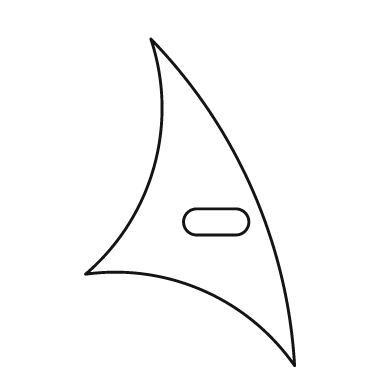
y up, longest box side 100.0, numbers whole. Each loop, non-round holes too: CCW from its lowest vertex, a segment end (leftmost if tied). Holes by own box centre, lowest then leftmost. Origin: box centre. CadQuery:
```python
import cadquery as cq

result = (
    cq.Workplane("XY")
    .moveTo(32.0, -50.0)
    .threePointArc((19.0, 4.0), (-12.0, 50.0))
    .threePointArc((-11.0, 11.0), (-32.0, -22.0))
    .threePointArc((4.0, -27.0), (32.0, -50.0))
    .close()
    .moveTo(2.0, -10.0)
    .lineTo(14.0, -10.0)
    .threePointArc((18.0, -6.0), (14.0, -2.0))
    .lineTo(2.0, -2.0)
    .threePointArc((-2.0, -6.0), (2.0, -10.0))
    .close()
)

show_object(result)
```